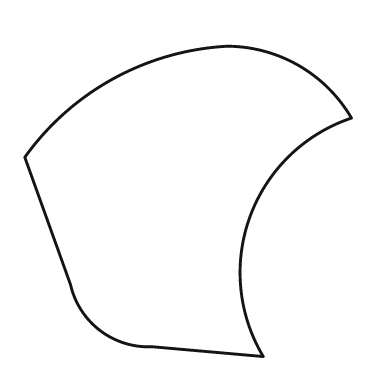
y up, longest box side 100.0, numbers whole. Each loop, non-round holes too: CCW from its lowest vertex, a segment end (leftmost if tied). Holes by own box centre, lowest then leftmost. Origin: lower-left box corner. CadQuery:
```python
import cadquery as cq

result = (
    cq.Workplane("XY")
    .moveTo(73.0, 0.0)
    .threePointArc((69.0, 43.0), (100.0, 73.0))
    .threePointArc((84.0, 89.0), (62.0, 95.0))
    .threePointArc((27.0, 85.0), (0.0, 61.0))
    .lineTo(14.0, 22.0)
    .threePointArc((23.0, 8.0), (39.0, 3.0))
    .close()
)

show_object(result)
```